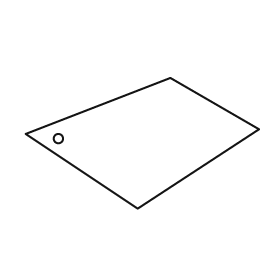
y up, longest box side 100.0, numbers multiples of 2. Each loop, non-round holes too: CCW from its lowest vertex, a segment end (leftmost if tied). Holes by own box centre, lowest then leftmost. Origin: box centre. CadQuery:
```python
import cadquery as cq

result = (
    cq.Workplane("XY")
    .moveTo(-2.0, -28.0)
    .lineTo(50.0, 6.0)
    .lineTo(12.0, 28.0)
    .lineTo(-50.0, 4.0)
    .close()
    .moveTo(-36.0, 2.0)
    .circle(2.0)
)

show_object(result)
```